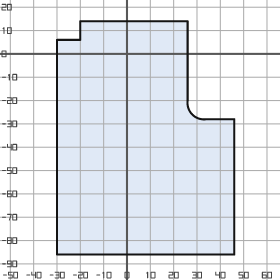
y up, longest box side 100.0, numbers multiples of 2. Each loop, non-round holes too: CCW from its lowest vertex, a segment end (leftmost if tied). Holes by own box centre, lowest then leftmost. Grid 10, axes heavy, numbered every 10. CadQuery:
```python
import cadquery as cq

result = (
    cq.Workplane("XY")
    .moveTo(-30.0, -86.0)
    .lineTo(46.0, -86.0)
    .lineTo(46.0, -28.0)
    .lineTo(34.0, -28.0)
    .threePointArc((28.0, -26.0), (26.0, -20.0))
    .lineTo(26.0, 14.0)
    .lineTo(-20.0, 14.0)
    .lineTo(-20.0, 6.0)
    .lineTo(-30.0, 6.0)
    .close()
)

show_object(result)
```